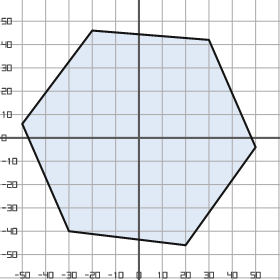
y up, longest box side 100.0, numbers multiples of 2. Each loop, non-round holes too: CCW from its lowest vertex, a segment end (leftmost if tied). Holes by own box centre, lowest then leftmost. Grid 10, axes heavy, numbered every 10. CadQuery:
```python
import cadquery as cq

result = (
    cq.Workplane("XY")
    .moveTo(20.0, -46.0)
    .lineTo(50.0, -4.0)
    .lineTo(30.0, 42.0)
    .lineTo(-20.0, 46.0)
    .lineTo(-50.0, 6.0)
    .lineTo(-30.0, -40.0)
    .close()
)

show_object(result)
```